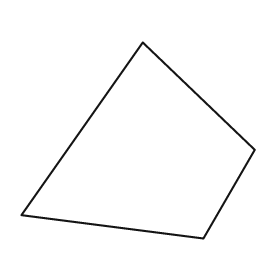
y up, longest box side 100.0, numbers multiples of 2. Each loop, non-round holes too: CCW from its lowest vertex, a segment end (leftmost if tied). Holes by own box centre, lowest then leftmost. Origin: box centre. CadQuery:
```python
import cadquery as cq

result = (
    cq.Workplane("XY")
    .moveTo(28.0, -42.0)
    .lineTo(50.0, -4.0)
    .lineTo(2.0, 42.0)
    .lineTo(-50.0, -32.0)
    .close()
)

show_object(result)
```